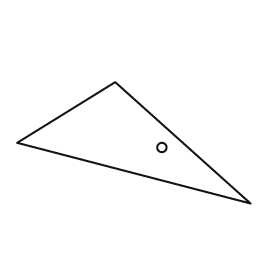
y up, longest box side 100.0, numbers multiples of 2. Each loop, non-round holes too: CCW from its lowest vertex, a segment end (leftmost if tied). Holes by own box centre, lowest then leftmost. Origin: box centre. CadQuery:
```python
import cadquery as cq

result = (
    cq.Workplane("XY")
    .moveTo(50.0, -26.0)
    .lineTo(-8.0, 26.0)
    .lineTo(-50.0, 0.0)
    .close()
    .moveTo(12.0, -2.0)
    .circle(2.0)
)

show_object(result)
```